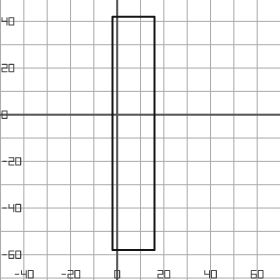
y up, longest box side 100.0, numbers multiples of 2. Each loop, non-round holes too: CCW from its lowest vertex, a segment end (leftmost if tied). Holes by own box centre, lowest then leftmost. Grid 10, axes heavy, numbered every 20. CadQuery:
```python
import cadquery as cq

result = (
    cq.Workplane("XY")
    .moveTo(-2.0, -58.0)
    .lineTo(16.0, -58.0)
    .lineTo(16.0, 42.0)
    .lineTo(-2.0, 42.0)
    .close()
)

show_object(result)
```